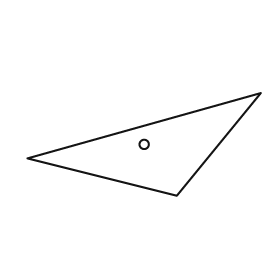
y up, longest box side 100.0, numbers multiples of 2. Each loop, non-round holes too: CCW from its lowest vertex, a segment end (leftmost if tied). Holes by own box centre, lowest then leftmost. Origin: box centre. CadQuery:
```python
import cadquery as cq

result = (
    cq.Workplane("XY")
    .moveTo(14.0, -22.0)
    .lineTo(50.0, 22.0)
    .lineTo(-50.0, -6.0)
    .close()
    .moveTo(0.0, 0.0)
    .circle(2.0)
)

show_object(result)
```